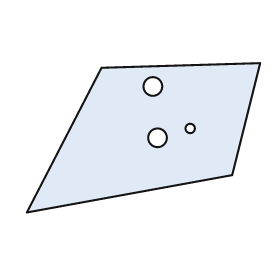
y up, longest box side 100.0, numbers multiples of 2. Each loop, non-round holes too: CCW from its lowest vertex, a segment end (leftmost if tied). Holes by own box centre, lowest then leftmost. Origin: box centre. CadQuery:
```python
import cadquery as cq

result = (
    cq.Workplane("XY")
    .moveTo(-50.0, -32.0)
    .lineTo(38.0, -16.0)
    .lineTo(50.0, 32.0)
    .lineTo(-18.0, 30.0)
    .close()
    .moveTo(6.0, 0.0)
    .circle(4.0)
    .moveTo(20.0, 4.0)
    .circle(2.0)
    .moveTo(4.0, 22.0)
    .circle(4.0)
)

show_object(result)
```